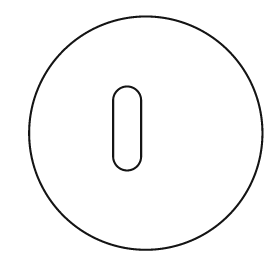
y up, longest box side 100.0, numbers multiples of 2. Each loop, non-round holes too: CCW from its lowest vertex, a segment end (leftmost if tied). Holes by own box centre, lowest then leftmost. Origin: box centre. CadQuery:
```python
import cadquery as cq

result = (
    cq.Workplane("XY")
    .moveTo(0.0, 0.0)
    .circle(50.0)
    .moveTo(-14.0, -10.0)
    .threePointArc((-8.0, -16.0), (-2.0, -10.0))
    .lineTo(-2.0, 14.0)
    .threePointArc((-8.0, 20.0), (-14.0, 14.0))
    .close()
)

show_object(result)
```